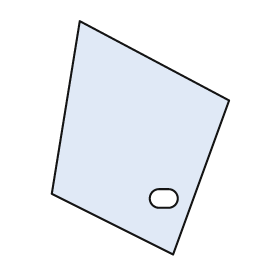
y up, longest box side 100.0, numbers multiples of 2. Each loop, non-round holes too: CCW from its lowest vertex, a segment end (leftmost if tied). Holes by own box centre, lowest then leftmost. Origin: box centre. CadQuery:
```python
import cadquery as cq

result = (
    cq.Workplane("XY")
    .moveTo(14.0, -50.0)
    .lineTo(38.0, 16.0)
    .lineTo(-26.0, 50.0)
    .lineTo(-38.0, -24.0)
    .close()
    .moveTo(8.0, -30.0)
    .lineTo(12.0, -30.0)
    .threePointArc((16.0, -26.0), (12.0, -22.0))
    .lineTo(8.0, -22.0)
    .threePointArc((4.0, -26.0), (8.0, -30.0))
    .close()
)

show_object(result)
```